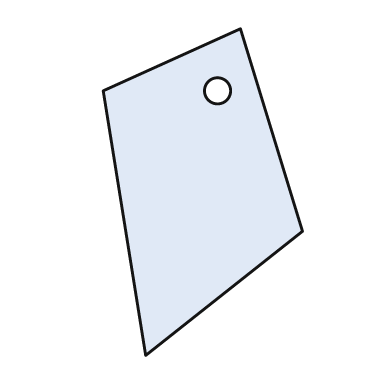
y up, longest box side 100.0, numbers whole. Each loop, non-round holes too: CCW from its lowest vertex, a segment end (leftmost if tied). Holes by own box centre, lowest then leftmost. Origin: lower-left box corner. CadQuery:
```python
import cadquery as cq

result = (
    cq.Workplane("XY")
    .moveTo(13.0, 0.0)
    .lineTo(61.0, 38.0)
    .lineTo(42.0, 100.0)
    .lineTo(0.0, 81.0)
    .close()
    .moveTo(35.0, 81.0)
    .circle(4.0)
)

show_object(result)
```